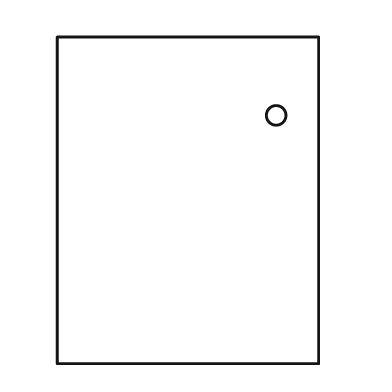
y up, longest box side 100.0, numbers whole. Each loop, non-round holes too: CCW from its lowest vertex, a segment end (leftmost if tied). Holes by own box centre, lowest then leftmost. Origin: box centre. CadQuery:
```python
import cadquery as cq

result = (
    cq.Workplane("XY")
    .moveTo(-40.0, -50.0)
    .lineTo(40.0, -50.0)
    .lineTo(40.0, 50.0)
    .lineTo(-40.0, 50.0)
    .close()
    .moveTo(27.0, 26.0)
    .circle(3.0)
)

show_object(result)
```